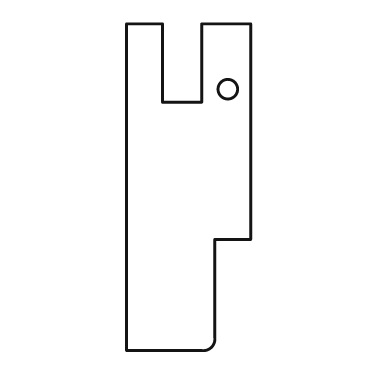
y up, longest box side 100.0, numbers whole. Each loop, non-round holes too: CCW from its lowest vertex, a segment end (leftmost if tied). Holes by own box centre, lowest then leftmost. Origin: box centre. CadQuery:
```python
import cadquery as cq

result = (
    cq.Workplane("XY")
    .moveTo(-19.0, -50.0)
    .lineTo(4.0, -50.0)
    .threePointArc((7.0, -49.0), (8.0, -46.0))
    .lineTo(8.0, -16.0)
    .lineTo(19.0, -16.0)
    .lineTo(19.0, 50.0)
    .lineTo(4.0, 50.0)
    .lineTo(4.0, 26.0)
    .lineTo(-8.0, 26.0)
    .lineTo(-8.0, 50.0)
    .lineTo(-19.0, 50.0)
    .close()
    .moveTo(12.0, 30.0)
    .circle(3.0)
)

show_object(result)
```